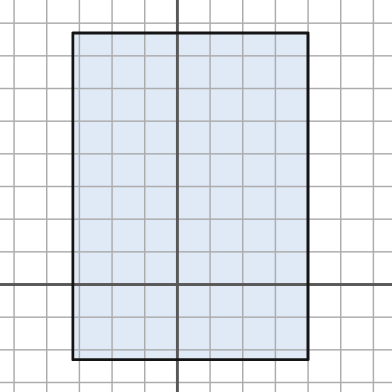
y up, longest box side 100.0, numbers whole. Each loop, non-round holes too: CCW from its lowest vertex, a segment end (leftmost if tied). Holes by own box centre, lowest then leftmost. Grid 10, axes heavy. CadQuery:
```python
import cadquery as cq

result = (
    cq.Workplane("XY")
    .moveTo(-32.0, -23.0)
    .lineTo(40.0, -23.0)
    .lineTo(40.0, 77.0)
    .lineTo(-32.0, 77.0)
    .close()
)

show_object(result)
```